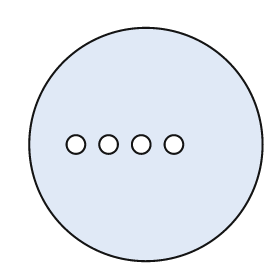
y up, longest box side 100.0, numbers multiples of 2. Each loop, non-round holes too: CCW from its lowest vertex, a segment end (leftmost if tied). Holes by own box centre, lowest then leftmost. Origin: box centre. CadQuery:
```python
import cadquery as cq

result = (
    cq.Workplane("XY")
    .moveTo(0.0, 0.0)
    .circle(50.0)
    .moveTo(-30.0, 0.0)
    .circle(4.0)
    .moveTo(-16.0, 0.0)
    .circle(4.0)
    .moveTo(-2.0, 0.0)
    .circle(4.0)
    .moveTo(12.0, 0.0)
    .circle(4.0)
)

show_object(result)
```